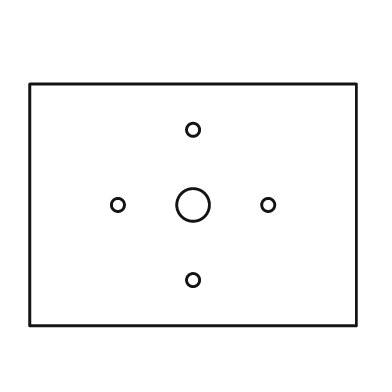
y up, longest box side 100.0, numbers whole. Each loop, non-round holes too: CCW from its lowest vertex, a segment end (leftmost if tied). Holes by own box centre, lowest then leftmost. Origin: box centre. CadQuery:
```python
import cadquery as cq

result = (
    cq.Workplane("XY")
    .moveTo(-50.0, -37.0)
    .lineTo(50.0, -37.0)
    .lineTo(50.0, 37.0)
    .lineTo(-50.0, 37.0)
    .close()
    .moveTo(0.0, -23.0)
    .circle(2.0)
    .moveTo(-23.0, 0.0)
    .circle(2.0)
    .moveTo(0.0, 0.0)
    .circle(5.0)
    .moveTo(23.0, 0.0)
    .circle(2.0)
    .moveTo(0.0, 23.0)
    .circle(2.0)
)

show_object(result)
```